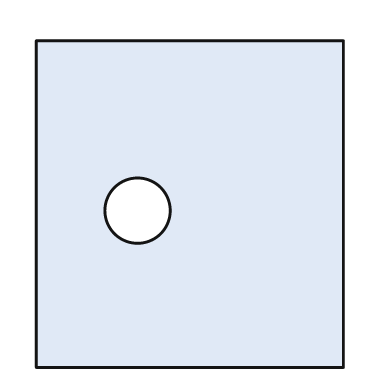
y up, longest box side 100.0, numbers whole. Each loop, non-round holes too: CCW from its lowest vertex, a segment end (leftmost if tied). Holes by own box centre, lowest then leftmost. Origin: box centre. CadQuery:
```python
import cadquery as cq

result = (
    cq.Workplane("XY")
    .moveTo(-47.0, -50.0)
    .lineTo(47.0, -50.0)
    .lineTo(47.0, 50.0)
    .lineTo(-47.0, 50.0)
    .close()
    .moveTo(-16.0, -2.0)
    .circle(10.0)
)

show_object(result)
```